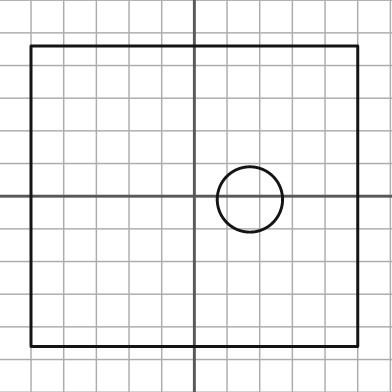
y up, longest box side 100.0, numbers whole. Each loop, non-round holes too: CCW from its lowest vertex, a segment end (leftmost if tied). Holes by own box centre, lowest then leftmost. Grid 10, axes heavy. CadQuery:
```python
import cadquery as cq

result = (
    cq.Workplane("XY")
    .moveTo(-50.0, -46.0)
    .lineTo(50.0, -46.0)
    .lineTo(50.0, 46.0)
    .lineTo(-50.0, 46.0)
    .close()
    .moveTo(17.0, -1.0)
    .circle(10.0)
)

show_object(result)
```